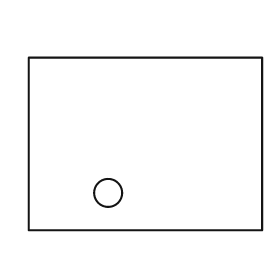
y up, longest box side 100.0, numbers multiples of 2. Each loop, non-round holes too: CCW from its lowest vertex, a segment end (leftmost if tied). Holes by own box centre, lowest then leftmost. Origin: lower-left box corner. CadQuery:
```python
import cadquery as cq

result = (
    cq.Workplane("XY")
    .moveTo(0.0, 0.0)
    .lineTo(100.0, 0.0)
    .lineTo(100.0, 74.0)
    .lineTo(0.0, 74.0)
    .close()
    .moveTo(34.0, 16.0)
    .circle(6.0)
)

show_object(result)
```